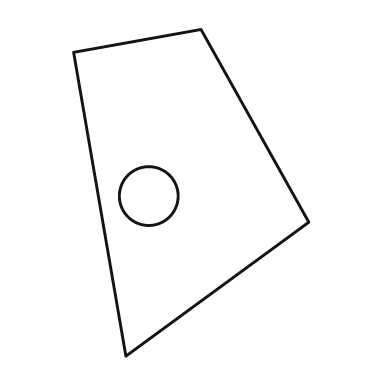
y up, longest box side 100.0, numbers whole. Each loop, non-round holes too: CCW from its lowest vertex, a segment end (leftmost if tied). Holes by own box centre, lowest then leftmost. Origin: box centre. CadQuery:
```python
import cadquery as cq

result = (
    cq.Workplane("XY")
    .moveTo(-20.0, -50.0)
    .lineTo(36.0, -9.0)
    .lineTo(3.0, 50.0)
    .lineTo(-36.0, 43.0)
    .close()
    .moveTo(-13.0, -1.0)
    .circle(9.0)
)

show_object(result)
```